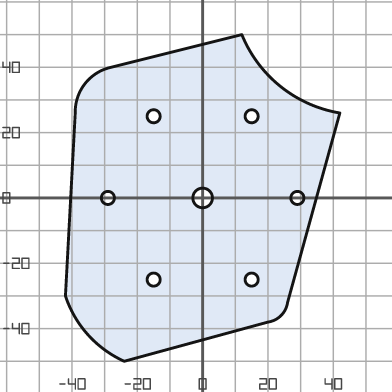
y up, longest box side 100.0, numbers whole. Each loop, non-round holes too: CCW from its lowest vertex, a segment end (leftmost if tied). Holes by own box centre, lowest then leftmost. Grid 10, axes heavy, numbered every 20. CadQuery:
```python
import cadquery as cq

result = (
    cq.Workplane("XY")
    .moveTo(-24.0, -50.0)
    .lineTo(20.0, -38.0)
    .threePointArc((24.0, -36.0), (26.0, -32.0))
    .lineTo(42.0, 26.0)
    .threePointArc((24.0, 34.0), (12.0, 50.0))
    .lineTo(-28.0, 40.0)
    .threePointArc((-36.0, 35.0), (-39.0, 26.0))
    .lineTo(-42.0, -30.0)
    .threePointArc((-35.0, -42.0), (-24.0, -50.0))
    .close()
    .moveTo(-15.0, -25.0)
    .circle(2.0)
    .moveTo(15.0, -25.0)
    .circle(2.0)
    .moveTo(-29.0, 0.0)
    .circle(2.0)
    .moveTo(0.0, 0.0)
    .circle(3.0)
    .moveTo(29.0, 0.0)
    .circle(2.0)
    .moveTo(-15.0, 25.0)
    .circle(2.0)
    .moveTo(15.0, 25.0)
    .circle(2.0)
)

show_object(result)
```